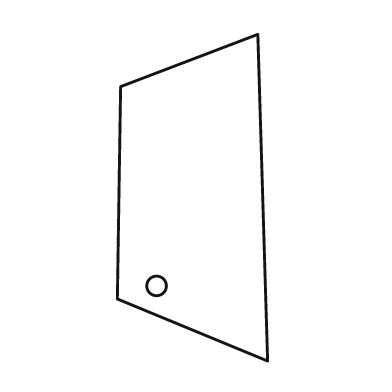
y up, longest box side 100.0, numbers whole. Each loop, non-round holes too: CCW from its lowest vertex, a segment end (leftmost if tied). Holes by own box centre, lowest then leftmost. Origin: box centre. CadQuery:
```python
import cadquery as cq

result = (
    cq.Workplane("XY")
    .moveTo(23.0, -50.0)
    .lineTo(20.0, 50.0)
    .lineTo(-22.0, 34.0)
    .lineTo(-23.0, -31.0)
    .close()
    .moveTo(-11.0, -27.0)
    .circle(3.0)
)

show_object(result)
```